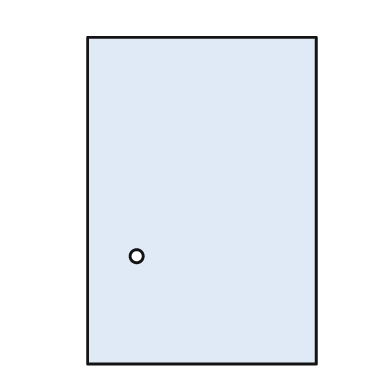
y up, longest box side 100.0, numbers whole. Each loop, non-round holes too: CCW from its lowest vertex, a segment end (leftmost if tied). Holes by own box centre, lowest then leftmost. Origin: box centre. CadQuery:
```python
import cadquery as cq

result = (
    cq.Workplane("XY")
    .moveTo(-35.0, -50.0)
    .lineTo(35.0, -50.0)
    .lineTo(35.0, 50.0)
    .lineTo(-35.0, 50.0)
    .close()
    .moveTo(-20.0, -17.0)
    .circle(2.0)
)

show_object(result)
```